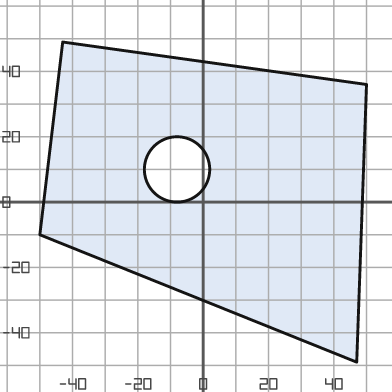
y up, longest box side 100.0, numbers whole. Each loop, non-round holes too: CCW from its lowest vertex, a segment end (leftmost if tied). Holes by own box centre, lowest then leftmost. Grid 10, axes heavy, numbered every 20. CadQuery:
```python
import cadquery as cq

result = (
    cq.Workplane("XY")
    .moveTo(47.0, -49.0)
    .lineTo(50.0, 36.0)
    .lineTo(-43.0, 49.0)
    .lineTo(-50.0, -10.0)
    .close()
    .moveTo(-8.0, 10.0)
    .circle(10.0)
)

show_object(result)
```